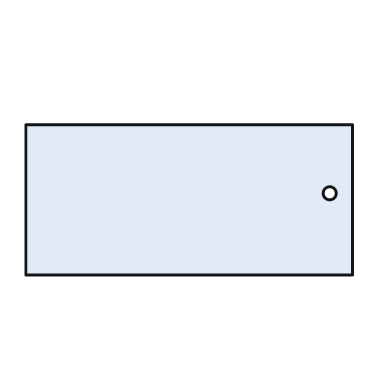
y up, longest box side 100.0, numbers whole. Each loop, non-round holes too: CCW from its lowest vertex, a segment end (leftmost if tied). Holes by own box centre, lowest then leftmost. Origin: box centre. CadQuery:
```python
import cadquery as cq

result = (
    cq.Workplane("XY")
    .moveTo(-50.0, -23.0)
    .lineTo(50.0, -23.0)
    .lineTo(50.0, 23.0)
    .lineTo(-50.0, 23.0)
    .close()
    .moveTo(43.0, 2.0)
    .circle(2.0)
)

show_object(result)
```